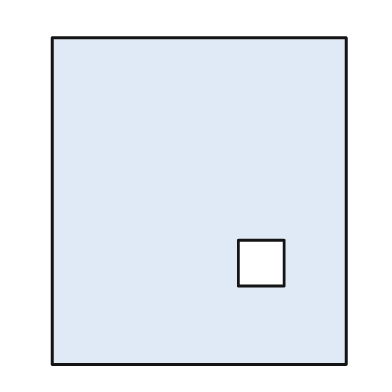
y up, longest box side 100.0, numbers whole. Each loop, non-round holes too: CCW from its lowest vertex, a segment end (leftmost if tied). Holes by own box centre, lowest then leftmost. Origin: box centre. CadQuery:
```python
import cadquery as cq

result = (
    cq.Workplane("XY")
    .moveTo(-45.0, -50.0)
    .lineTo(45.0, -50.0)
    .lineTo(45.0, 50.0)
    .lineTo(-45.0, 50.0)
    .close()
    .moveTo(12.0, -26.0)
    .lineTo(26.0, -26.0)
    .lineTo(26.0, -12.0)
    .lineTo(12.0, -12.0)
    .close()
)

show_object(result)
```